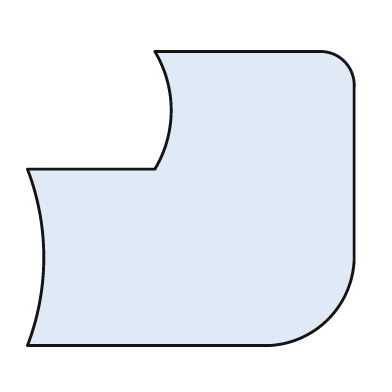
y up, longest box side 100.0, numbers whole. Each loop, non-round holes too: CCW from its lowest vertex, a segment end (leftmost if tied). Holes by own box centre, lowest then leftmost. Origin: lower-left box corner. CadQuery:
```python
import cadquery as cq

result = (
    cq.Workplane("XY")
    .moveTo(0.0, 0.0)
    .lineTo(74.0, 0.0)
    .threePointArc((92.0, 8.0), (100.0, 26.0))
    .lineTo(100.0, 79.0)
    .threePointArc((97.0, 87.0), (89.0, 90.0))
    .lineTo(39.0, 90.0)
    .threePointArc((44.0, 72.0), (39.0, 54.0))
    .lineTo(0.0, 54.0)
    .threePointArc((5.0, 27.0), (0.0, 0.0))
    .close()
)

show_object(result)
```